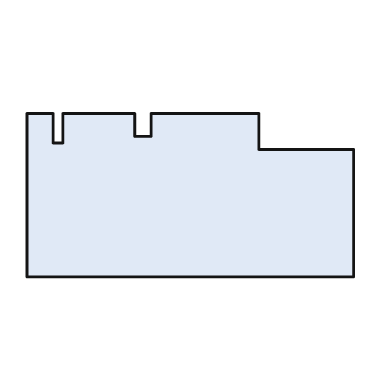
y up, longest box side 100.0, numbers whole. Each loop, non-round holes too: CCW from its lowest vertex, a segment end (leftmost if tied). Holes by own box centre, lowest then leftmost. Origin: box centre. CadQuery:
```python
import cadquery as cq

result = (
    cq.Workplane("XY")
    .moveTo(-50.0, -25.0)
    .lineTo(50.0, -25.0)
    .lineTo(50.0, 14.0)
    .lineTo(21.0, 14.0)
    .lineTo(21.0, 25.0)
    .lineTo(-12.0, 25.0)
    .lineTo(-12.0, 18.0)
    .lineTo(-17.0, 18.0)
    .lineTo(-17.0, 25.0)
    .lineTo(-39.0, 25.0)
    .lineTo(-39.0, 16.0)
    .lineTo(-42.0, 16.0)
    .lineTo(-42.0, 25.0)
    .lineTo(-50.0, 25.0)
    .close()
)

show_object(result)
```